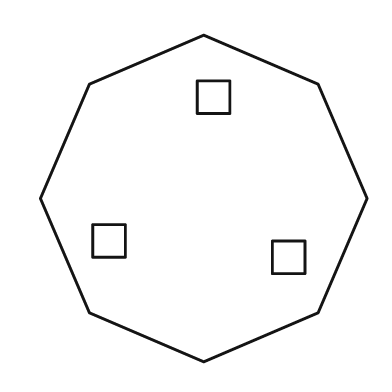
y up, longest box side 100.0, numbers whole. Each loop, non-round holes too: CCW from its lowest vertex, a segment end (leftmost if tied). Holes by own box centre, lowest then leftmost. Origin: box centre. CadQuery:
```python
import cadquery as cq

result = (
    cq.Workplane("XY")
    .moveTo(0.0, -50.0)
    .lineTo(35.0, -35.0)
    .lineTo(50.0, 0.0)
    .lineTo(35.0, 35.0)
    .lineTo(0.0, 50.0)
    .lineTo(-35.0, 35.0)
    .lineTo(-50.0, 0.0)
    .lineTo(-35.0, -35.0)
    .close()
    .moveTo(21.0, -23.0)
    .lineTo(31.0, -23.0)
    .lineTo(31.0, -13.0)
    .lineTo(21.0, -13.0)
    .close()
    .moveTo(-34.0, -18.0)
    .lineTo(-24.0, -18.0)
    .lineTo(-24.0, -8.0)
    .lineTo(-34.0, -8.0)
    .close()
    .moveTo(-2.0, 26.0)
    .lineTo(8.0, 26.0)
    .lineTo(8.0, 36.0)
    .lineTo(-2.0, 36.0)
    .close()
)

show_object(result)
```